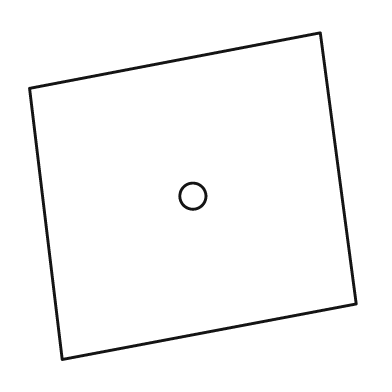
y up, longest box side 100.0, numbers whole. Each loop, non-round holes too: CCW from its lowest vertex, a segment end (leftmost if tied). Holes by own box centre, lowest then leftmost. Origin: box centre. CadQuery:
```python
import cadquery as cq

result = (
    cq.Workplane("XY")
    .moveTo(-40.0, -50.0)
    .lineTo(50.0, -33.0)
    .lineTo(39.0, 50.0)
    .lineTo(-50.0, 33.0)
    .close()
    .moveTo(0.0, 0.0)
    .circle(4.0)
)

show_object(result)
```